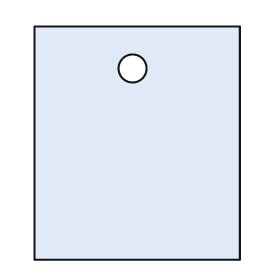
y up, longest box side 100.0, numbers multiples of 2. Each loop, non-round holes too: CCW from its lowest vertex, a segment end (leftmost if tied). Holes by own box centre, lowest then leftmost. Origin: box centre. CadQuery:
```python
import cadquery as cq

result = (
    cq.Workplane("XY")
    .moveTo(-44.0, -50.0)
    .lineTo(44.0, -50.0)
    .lineTo(44.0, 50.0)
    .lineTo(-44.0, 50.0)
    .close()
    .moveTo(-2.0, 32.0)
    .circle(6.0)
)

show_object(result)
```